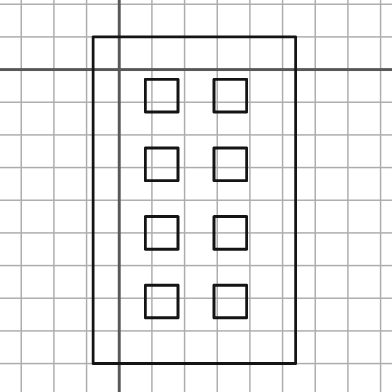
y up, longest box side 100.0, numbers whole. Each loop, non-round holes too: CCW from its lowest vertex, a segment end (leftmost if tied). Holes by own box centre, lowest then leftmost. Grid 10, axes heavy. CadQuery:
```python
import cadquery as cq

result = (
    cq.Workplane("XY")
    .moveTo(-8.0, -90.0)
    .lineTo(54.0, -90.0)
    .lineTo(54.0, 10.0)
    .lineTo(-8.0, 10.0)
    .close()
    .moveTo(8.0, -76.0)
    .lineTo(18.0, -76.0)
    .lineTo(18.0, -66.0)
    .lineTo(8.0, -66.0)
    .close()
    .moveTo(29.0, -76.0)
    .lineTo(39.0, -76.0)
    .lineTo(39.0, -66.0)
    .lineTo(29.0, -66.0)
    .close()
    .moveTo(8.0, -55.0)
    .lineTo(18.0, -55.0)
    .lineTo(18.0, -45.0)
    .lineTo(8.0, -45.0)
    .close()
    .moveTo(29.0, -55.0)
    .lineTo(39.0, -55.0)
    .lineTo(39.0, -45.0)
    .lineTo(29.0, -45.0)
    .close()
    .moveTo(8.0, -34.0)
    .lineTo(18.0, -34.0)
    .lineTo(18.0, -24.0)
    .lineTo(8.0, -24.0)
    .close()
    .moveTo(29.0, -34.0)
    .lineTo(39.0, -34.0)
    .lineTo(39.0, -24.0)
    .lineTo(29.0, -24.0)
    .close()
    .moveTo(8.0, -13.0)
    .lineTo(18.0, -13.0)
    .lineTo(18.0, -3.0)
    .lineTo(8.0, -3.0)
    .close()
    .moveTo(29.0, -13.0)
    .lineTo(39.0, -13.0)
    .lineTo(39.0, -3.0)
    .lineTo(29.0, -3.0)
    .close()
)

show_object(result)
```